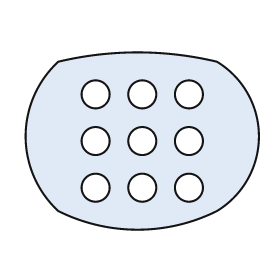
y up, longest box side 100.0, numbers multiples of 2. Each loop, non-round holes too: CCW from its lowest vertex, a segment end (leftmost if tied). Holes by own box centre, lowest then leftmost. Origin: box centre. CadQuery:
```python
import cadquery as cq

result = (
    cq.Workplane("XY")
    .moveTo(-36.0, -30.0)
    .threePointArc((-2.0, -38.0), (32.0, -30.0))
    .threePointArc((50.0, 2.0), (32.0, 34.0))
    .threePointArc((-2.0, 38.0), (-36.0, 34.0))
    .threePointArc((-50.0, 2.0), (-36.0, -30.0))
    .close()
    .moveTo(-20.0, -20.0)
    .circle(6.0)
    .moveTo(0.0, -20.0)
    .circle(6.0)
    .moveTo(20.0, -20.0)
    .circle(6.0)
    .moveTo(-20.0, 0.0)
    .circle(6.0)
    .moveTo(0.0, 0.0)
    .circle(6.0)
    .moveTo(20.0, 0.0)
    .circle(6.0)
    .moveTo(-20.0, 20.0)
    .circle(6.0)
    .moveTo(0.0, 20.0)
    .circle(6.0)
    .moveTo(20.0, 20.0)
    .circle(6.0)
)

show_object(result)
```